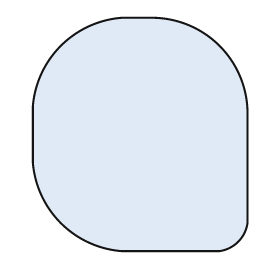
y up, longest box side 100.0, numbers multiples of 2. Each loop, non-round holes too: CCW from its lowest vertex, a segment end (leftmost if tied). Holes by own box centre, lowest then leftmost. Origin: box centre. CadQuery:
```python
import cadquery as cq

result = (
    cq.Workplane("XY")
    .moveTo(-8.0, -50.0)
    .lineTo(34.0, -50.0)
    .threePointArc((42.0, -46.0), (46.0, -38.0))
    .lineTo(46.0, 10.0)
    .threePointArc((34.0, 38.0), (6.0, 50.0))
    .lineTo(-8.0, 50.0)
    .threePointArc((-34.0, 38.0), (-46.0, 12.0))
    .lineTo(-46.0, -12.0)
    .threePointArc((-34.0, -38.0), (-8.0, -50.0))
    .close()
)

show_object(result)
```